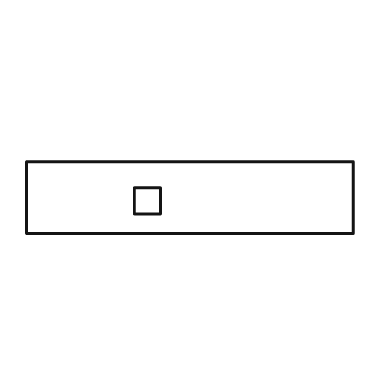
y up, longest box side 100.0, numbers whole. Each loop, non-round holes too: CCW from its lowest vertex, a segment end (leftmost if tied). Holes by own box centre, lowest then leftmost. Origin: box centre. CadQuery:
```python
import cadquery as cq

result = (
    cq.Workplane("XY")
    .moveTo(-50.0, -11.0)
    .lineTo(50.0, -11.0)
    .lineTo(50.0, 11.0)
    .lineTo(-50.0, 11.0)
    .close()
    .moveTo(-17.0, -5.0)
    .lineTo(-9.0, -5.0)
    .lineTo(-9.0, 3.0)
    .lineTo(-17.0, 3.0)
    .close()
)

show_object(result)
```